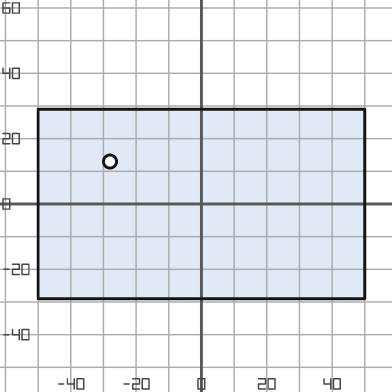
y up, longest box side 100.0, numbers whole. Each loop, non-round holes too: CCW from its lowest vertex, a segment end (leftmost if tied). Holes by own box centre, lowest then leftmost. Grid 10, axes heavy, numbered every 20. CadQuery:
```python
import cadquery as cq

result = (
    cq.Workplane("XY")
    .moveTo(-50.0, -29.0)
    .lineTo(50.0, -29.0)
    .lineTo(50.0, 29.0)
    .lineTo(-50.0, 29.0)
    .close()
    .moveTo(-28.0, 13.0)
    .circle(2.0)
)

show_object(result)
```